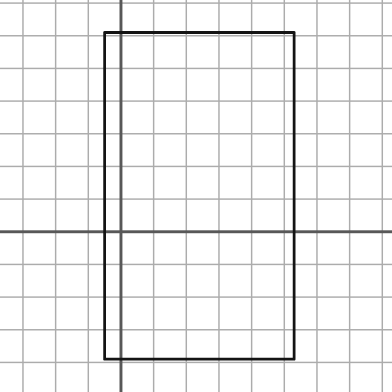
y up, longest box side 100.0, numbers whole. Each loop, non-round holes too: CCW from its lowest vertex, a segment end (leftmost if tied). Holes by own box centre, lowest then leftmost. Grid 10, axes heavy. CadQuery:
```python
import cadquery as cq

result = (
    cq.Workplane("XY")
    .moveTo(-5.0, -39.0)
    .lineTo(53.0, -39.0)
    .lineTo(53.0, 61.0)
    .lineTo(-5.0, 61.0)
    .close()
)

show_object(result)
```